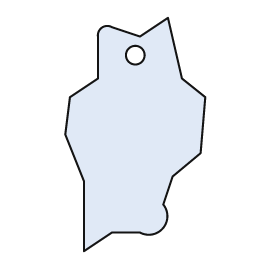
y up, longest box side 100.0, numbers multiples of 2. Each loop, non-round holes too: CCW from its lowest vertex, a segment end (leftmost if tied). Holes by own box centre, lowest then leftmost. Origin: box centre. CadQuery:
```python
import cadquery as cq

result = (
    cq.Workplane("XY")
    .moveTo(-22.0, -50.0)
    .lineTo(-10.0, -42.0)
    .lineTo(2.0, -42.0)
    .threePointArc((12.0, -40.0), (12.0, -30.0))
    .lineTo(16.0, -18.0)
    .lineTo(28.0, -8.0)
    .lineTo(30.0, 16.0)
    .lineTo(20.0, 24.0)
    .lineTo(14.0, 50.0)
    .lineTo(2.0, 42.0)
    .lineTo(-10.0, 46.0)
    .threePointArc((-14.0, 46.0), (-16.0, 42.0))
    .lineTo(-16.0, 24.0)
    .lineTo(-28.0, 16.0)
    .lineTo(-30.0, 0.0)
    .lineTo(-22.0, -20.0)
    .close()
    .moveTo(0.0, 34.0)
    .circle(4.0)
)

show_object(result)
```